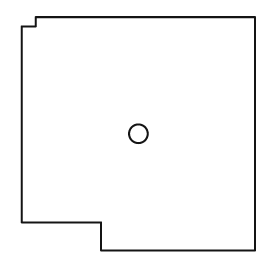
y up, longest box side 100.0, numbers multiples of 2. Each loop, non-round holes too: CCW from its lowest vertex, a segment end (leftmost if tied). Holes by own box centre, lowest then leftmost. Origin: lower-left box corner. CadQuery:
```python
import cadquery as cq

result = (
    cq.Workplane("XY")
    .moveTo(34.0, 0.0)
    .lineTo(100.0, 0.0)
    .lineTo(100.0, 100.0)
    .lineTo(6.0, 100.0)
    .lineTo(6.0, 96.0)
    .lineTo(0.0, 96.0)
    .lineTo(0.0, 12.0)
    .lineTo(34.0, 12.0)
    .close()
    .moveTo(50.0, 50.0)
    .circle(4.0)
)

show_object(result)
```